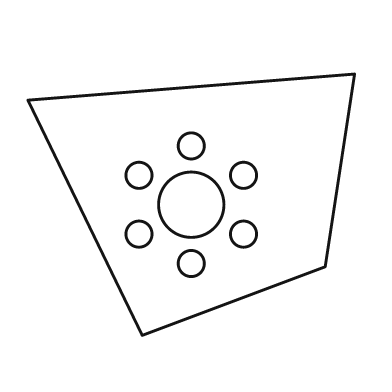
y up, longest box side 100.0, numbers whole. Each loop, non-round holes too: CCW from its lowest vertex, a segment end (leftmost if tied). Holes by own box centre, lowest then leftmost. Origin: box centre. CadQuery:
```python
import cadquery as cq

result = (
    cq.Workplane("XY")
    .moveTo(-15.0, -40.0)
    .lineTo(41.0, -19.0)
    .lineTo(50.0, 40.0)
    .lineTo(-50.0, 32.0)
    .close()
    .moveTo(0.0, -18.0)
    .circle(4.0)
    .moveTo(-16.0, -9.0)
    .circle(4.0)
    .moveTo(16.0, -9.0)
    .circle(4.0)
    .moveTo(0.0, 0.0)
    .circle(10.0)
    .moveTo(-16.0, 9.0)
    .circle(4.0)
    .moveTo(16.0, 9.0)
    .circle(4.0)
    .moveTo(0.0, 18.0)
    .circle(4.0)
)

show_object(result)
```